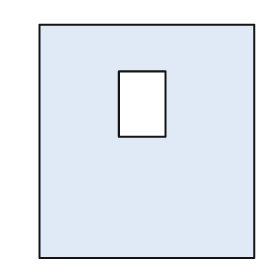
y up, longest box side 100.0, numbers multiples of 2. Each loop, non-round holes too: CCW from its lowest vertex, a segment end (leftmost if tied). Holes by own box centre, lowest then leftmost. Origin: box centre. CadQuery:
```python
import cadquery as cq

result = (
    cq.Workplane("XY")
    .moveTo(-46.0, -50.0)
    .lineTo(46.0, -50.0)
    .lineTo(46.0, 50.0)
    .lineTo(-46.0, 50.0)
    .close()
    .moveTo(-12.0, 2.0)
    .lineTo(8.0, 2.0)
    .lineTo(8.0, 30.0)
    .lineTo(-12.0, 30.0)
    .close()
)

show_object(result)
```